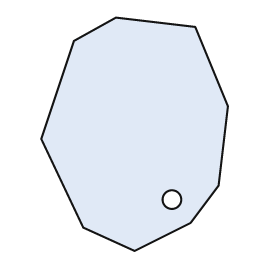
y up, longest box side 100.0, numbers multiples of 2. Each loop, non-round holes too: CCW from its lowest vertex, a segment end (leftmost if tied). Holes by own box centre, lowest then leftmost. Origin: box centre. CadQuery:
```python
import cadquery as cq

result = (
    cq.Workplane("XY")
    .moveTo(0.0, -50.0)
    .lineTo(24.0, -38.0)
    .lineTo(36.0, -22.0)
    .lineTo(40.0, 12.0)
    .lineTo(26.0, 46.0)
    .lineTo(-8.0, 50.0)
    .lineTo(-26.0, 40.0)
    .lineTo(-40.0, -2.0)
    .lineTo(-22.0, -40.0)
    .close()
    .moveTo(16.0, -28.0)
    .circle(4.0)
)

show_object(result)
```